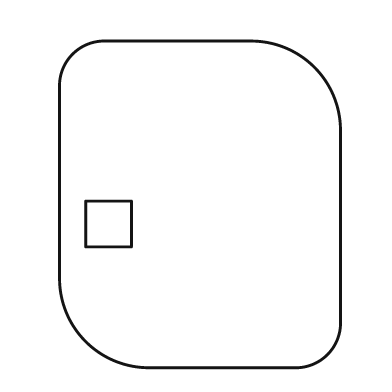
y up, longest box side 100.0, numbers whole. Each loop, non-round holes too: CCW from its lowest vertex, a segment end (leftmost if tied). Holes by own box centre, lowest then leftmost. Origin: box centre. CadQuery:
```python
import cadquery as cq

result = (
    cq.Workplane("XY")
    .moveTo(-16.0, -50.0)
    .lineTo(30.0, -50.0)
    .threePointArc((39.0, -46.0), (43.0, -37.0))
    .lineTo(43.0, 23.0)
    .threePointArc((35.0, 42.0), (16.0, 50.0))
    .lineTo(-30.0, 50.0)
    .threePointArc((-39.0, 46.0), (-43.0, 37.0))
    .lineTo(-43.0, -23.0)
    .threePointArc((-35.0, -42.0), (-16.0, -50.0))
    .close()
    .moveTo(-35.0, -13.0)
    .lineTo(-21.0, -13.0)
    .lineTo(-21.0, 1.0)
    .lineTo(-35.0, 1.0)
    .close()
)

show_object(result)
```